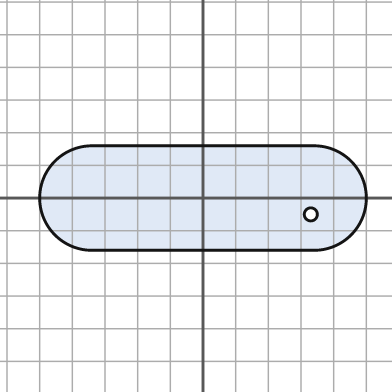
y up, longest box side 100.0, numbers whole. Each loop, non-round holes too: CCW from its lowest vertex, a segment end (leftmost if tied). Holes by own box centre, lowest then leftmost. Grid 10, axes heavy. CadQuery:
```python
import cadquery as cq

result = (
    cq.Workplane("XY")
    .moveTo(-34.0, -16.0)
    .lineTo(34.0, -16.0)
    .threePointArc((50.0, 0.0), (34.0, 16.0))
    .lineTo(-34.0, 16.0)
    .threePointArc((-50.0, 0.0), (-34.0, -16.0))
    .close()
    .moveTo(33.0, -5.0)
    .circle(2.0)
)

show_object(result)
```